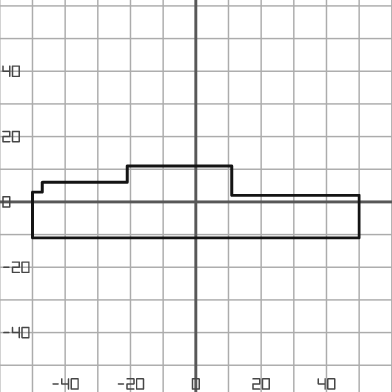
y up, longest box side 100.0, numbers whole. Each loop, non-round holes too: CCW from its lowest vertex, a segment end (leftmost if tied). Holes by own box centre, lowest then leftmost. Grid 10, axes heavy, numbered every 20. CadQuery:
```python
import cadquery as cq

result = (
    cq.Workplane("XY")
    .moveTo(-50.0, -11.0)
    .lineTo(50.0, -11.0)
    .lineTo(50.0, 2.0)
    .lineTo(11.0, 2.0)
    .lineTo(11.0, 11.0)
    .lineTo(-21.0, 11.0)
    .lineTo(-21.0, 6.0)
    .lineTo(-47.0, 6.0)
    .lineTo(-47.0, 3.0)
    .lineTo(-50.0, 3.0)
    .close()
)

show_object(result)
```